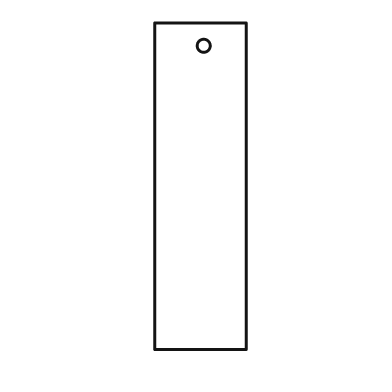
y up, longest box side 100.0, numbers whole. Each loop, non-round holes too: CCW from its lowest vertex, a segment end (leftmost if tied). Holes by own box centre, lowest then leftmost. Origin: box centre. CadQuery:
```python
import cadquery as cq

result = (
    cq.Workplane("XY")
    .moveTo(-14.0, -50.0)
    .lineTo(14.0, -50.0)
    .lineTo(14.0, 50.0)
    .lineTo(-14.0, 50.0)
    .close()
    .moveTo(1.0, 43.0)
    .circle(2.0)
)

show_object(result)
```